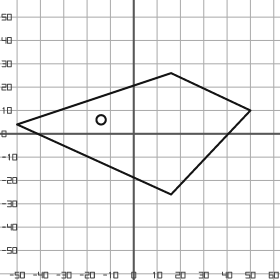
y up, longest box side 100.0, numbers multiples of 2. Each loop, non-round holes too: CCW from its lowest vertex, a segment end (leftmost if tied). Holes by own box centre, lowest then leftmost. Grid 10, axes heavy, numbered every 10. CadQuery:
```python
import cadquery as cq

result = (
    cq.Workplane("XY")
    .moveTo(16.0, -26.0)
    .lineTo(50.0, 10.0)
    .lineTo(16.0, 26.0)
    .lineTo(-50.0, 4.0)
    .close()
    .moveTo(-14.0, 6.0)
    .circle(2.0)
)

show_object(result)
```